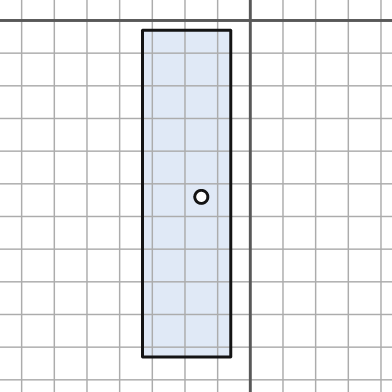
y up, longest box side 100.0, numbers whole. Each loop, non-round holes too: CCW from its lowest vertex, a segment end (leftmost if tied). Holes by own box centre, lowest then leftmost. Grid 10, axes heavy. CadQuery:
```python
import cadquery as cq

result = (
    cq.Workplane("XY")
    .moveTo(-33.0, -103.0)
    .lineTo(-6.0, -103.0)
    .lineTo(-6.0, -3.0)
    .lineTo(-33.0, -3.0)
    .close()
    .moveTo(-15.0, -54.0)
    .circle(2.0)
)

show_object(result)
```